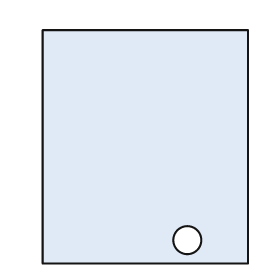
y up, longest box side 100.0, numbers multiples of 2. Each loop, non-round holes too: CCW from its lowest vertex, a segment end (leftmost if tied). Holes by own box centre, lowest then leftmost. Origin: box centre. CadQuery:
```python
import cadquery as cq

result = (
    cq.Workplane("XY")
    .moveTo(-44.0, -50.0)
    .lineTo(44.0, -50.0)
    .lineTo(44.0, 50.0)
    .lineTo(-44.0, 50.0)
    .close()
    .moveTo(18.0, -40.0)
    .circle(6.0)
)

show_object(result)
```